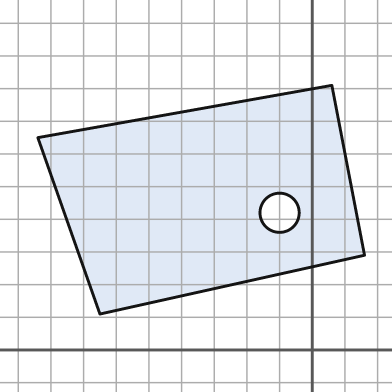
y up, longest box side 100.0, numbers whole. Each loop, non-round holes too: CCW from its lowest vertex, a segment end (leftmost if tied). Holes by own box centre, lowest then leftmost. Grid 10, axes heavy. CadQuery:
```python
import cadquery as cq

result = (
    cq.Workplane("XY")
    .moveTo(-65.0, 11.0)
    .lineTo(16.0, 29.0)
    .lineTo(6.0, 81.0)
    .lineTo(-84.0, 65.0)
    .close()
    .moveTo(-10.0, 42.0)
    .circle(6.0)
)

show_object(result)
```